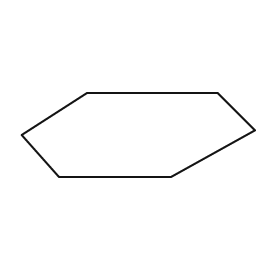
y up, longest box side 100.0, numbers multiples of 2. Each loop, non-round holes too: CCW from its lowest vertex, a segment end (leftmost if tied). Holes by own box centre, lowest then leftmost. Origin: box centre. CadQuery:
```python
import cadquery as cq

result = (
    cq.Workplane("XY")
    .moveTo(-34.0, -18.0)
    .lineTo(14.0, -18.0)
    .lineTo(50.0, 2.0)
    .lineTo(34.0, 18.0)
    .lineTo(-22.0, 18.0)
    .lineTo(-50.0, 0.0)
    .close()
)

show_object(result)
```